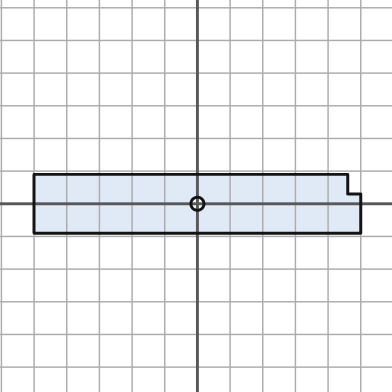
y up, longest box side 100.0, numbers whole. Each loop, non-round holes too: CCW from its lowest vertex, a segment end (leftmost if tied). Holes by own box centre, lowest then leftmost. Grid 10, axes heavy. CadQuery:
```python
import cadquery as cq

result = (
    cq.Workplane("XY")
    .moveTo(-50.0, -9.0)
    .lineTo(50.0, -9.0)
    .lineTo(50.0, 3.0)
    .lineTo(46.0, 3.0)
    .lineTo(46.0, 9.0)
    .lineTo(-50.0, 9.0)
    .close()
    .moveTo(0.0, 0.0)
    .circle(2.0)
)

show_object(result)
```